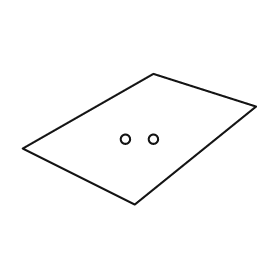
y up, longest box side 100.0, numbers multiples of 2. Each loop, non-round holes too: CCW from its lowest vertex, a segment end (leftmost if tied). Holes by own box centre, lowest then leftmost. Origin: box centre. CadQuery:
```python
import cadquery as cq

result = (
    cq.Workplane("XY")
    .moveTo(-2.0, -28.0)
    .lineTo(50.0, 14.0)
    .lineTo(6.0, 28.0)
    .lineTo(-50.0, -4.0)
    .close()
    .moveTo(-6.0, 0.0)
    .circle(2.0)
    .moveTo(6.0, 0.0)
    .circle(2.0)
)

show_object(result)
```